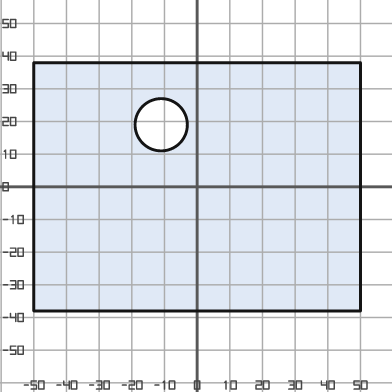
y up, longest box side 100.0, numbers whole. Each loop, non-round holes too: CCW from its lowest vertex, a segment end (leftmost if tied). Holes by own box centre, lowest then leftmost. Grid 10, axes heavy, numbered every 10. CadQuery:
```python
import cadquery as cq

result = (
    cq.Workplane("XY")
    .moveTo(-50.0, -38.0)
    .lineTo(50.0, -38.0)
    .lineTo(50.0, 38.0)
    .lineTo(-50.0, 38.0)
    .close()
    .moveTo(-11.0, 19.0)
    .circle(8.0)
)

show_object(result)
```